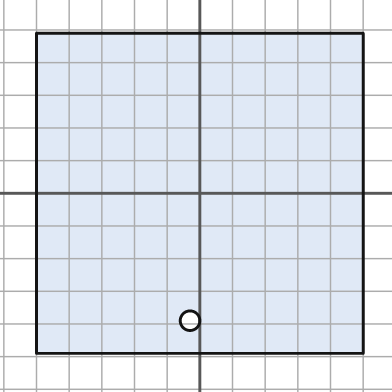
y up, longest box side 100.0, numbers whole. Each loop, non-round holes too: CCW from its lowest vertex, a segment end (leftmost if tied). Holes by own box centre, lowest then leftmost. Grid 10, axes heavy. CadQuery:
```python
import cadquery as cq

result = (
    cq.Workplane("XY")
    .moveTo(-50.0, -49.0)
    .lineTo(50.0, -49.0)
    .lineTo(50.0, 49.0)
    .lineTo(-50.0, 49.0)
    .close()
    .moveTo(-3.0, -39.0)
    .circle(3.0)
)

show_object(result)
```